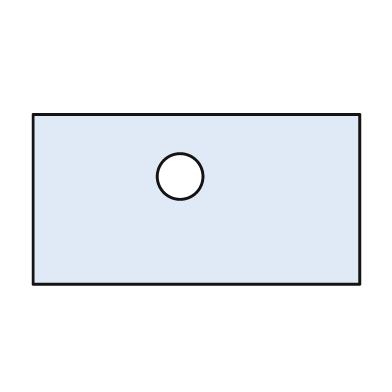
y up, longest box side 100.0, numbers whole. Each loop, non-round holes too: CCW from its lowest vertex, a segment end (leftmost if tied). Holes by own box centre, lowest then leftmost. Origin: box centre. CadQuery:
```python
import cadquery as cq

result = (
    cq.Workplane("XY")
    .moveTo(-50.0, -26.0)
    .lineTo(50.0, -26.0)
    .lineTo(50.0, 26.0)
    .lineTo(-50.0, 26.0)
    .close()
    .moveTo(-5.0, 7.0)
    .circle(7.0)
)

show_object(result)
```